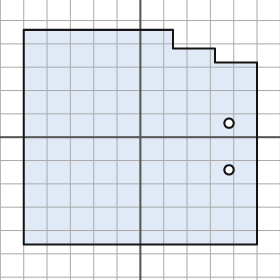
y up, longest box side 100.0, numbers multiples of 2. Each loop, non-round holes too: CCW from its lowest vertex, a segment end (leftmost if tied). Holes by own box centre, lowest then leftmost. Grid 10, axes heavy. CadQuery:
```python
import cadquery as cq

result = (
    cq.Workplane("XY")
    .moveTo(-50.0, -46.0)
    .lineTo(50.0, -46.0)
    .lineTo(50.0, 32.0)
    .lineTo(32.0, 32.0)
    .lineTo(32.0, 38.0)
    .lineTo(14.0, 38.0)
    .lineTo(14.0, 46.0)
    .lineTo(-50.0, 46.0)
    .close()
    .moveTo(38.0, -14.0)
    .circle(2.0)
    .moveTo(38.0, 6.0)
    .circle(2.0)
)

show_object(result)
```